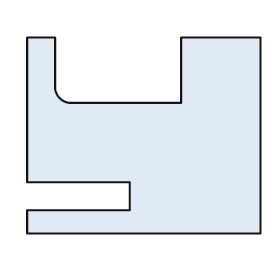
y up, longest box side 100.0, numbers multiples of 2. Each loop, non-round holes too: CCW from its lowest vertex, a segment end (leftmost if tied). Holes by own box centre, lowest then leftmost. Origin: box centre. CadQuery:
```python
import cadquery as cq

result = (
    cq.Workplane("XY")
    .moveTo(-50.0, -42.0)
    .lineTo(50.0, -42.0)
    .lineTo(50.0, 42.0)
    .lineTo(16.0, 42.0)
    .lineTo(16.0, 14.0)
    .lineTo(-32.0, 14.0)
    .threePointArc((-36.0, 16.0), (-38.0, 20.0))
    .lineTo(-38.0, 42.0)
    .lineTo(-50.0, 42.0)
    .lineTo(-50.0, -20.0)
    .lineTo(-6.0, -20.0)
    .lineTo(-6.0, -32.0)
    .lineTo(-50.0, -32.0)
    .close()
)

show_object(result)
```